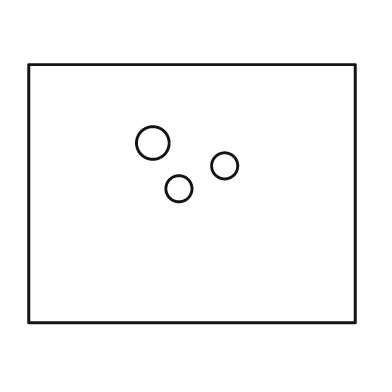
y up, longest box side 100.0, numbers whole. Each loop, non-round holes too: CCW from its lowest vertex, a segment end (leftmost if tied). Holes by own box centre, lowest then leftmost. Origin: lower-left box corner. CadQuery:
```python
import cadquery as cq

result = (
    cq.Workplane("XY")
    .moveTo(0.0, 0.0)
    .lineTo(100.0, 0.0)
    .lineTo(100.0, 79.0)
    .lineTo(0.0, 79.0)
    .close()
    .moveTo(46.0, 41.0)
    .circle(4.0)
    .moveTo(60.0, 48.0)
    .circle(4.0)
    .moveTo(38.0, 55.0)
    .circle(5.0)
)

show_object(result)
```